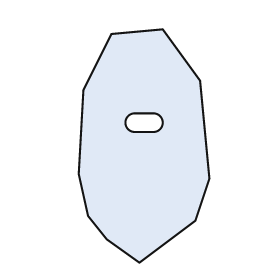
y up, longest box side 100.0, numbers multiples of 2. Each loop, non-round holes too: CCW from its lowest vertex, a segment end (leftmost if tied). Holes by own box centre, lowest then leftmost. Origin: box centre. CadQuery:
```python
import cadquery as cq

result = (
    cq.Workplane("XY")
    .moveTo(-2.0, -50.0)
    .lineTo(22.0, -32.0)
    .lineTo(28.0, -14.0)
    .lineTo(24.0, 28.0)
    .lineTo(8.0, 50.0)
    .lineTo(-14.0, 48.0)
    .lineTo(-26.0, 24.0)
    .lineTo(-28.0, -12.0)
    .lineTo(-24.0, -30.0)
    .lineTo(-16.0, -40.0)
    .close()
    .moveTo(-4.0, 6.0)
    .lineTo(4.0, 6.0)
    .threePointArc((8.0, 10.0), (4.0, 14.0))
    .lineTo(-4.0, 14.0)
    .threePointArc((-8.0, 10.0), (-4.0, 6.0))
    .close()
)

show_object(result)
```